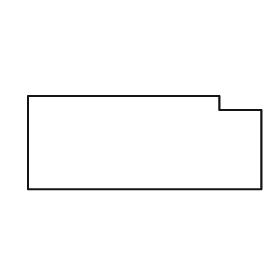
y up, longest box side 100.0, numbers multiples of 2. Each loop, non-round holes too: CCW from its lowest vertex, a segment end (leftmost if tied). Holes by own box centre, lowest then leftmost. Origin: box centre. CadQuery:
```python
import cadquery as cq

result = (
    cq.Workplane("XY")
    .moveTo(-50.0, -20.0)
    .lineTo(50.0, -20.0)
    .lineTo(50.0, 14.0)
    .lineTo(32.0, 14.0)
    .lineTo(32.0, 20.0)
    .lineTo(-50.0, 20.0)
    .close()
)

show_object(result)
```